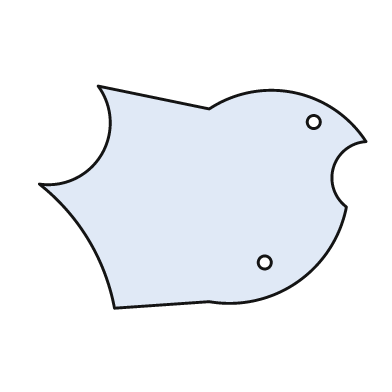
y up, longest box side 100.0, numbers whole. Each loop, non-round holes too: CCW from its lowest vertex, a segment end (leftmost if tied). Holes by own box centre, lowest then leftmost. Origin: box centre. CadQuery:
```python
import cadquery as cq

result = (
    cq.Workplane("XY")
    .moveTo(-27.0, -34.0)
    .lineTo(2.0, -32.0)
    .threePointArc((29.0, -26.0), (44.0, -3.0))
    .threePointArc((40.0, 9.0), (50.0, 17.0))
    .threePointArc((28.0, 32.0), (2.0, 27.0))
    .lineTo(-32.0, 34.0)
    .threePointArc((-31.0, 13.0), (-50.0, 4.0))
    .threePointArc((-35.0, -13.0), (-27.0, -34.0))
    .close()
    .moveTo(19.0, -20.0)
    .circle(2.0)
    .moveTo(34.0, 23.0)
    .circle(2.0)
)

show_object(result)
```